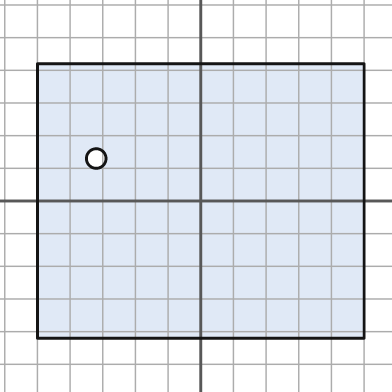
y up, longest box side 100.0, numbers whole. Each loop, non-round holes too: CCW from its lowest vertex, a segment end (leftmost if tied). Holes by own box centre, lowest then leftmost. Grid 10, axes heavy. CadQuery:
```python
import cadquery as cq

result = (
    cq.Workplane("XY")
    .moveTo(-50.0, -42.0)
    .lineTo(50.0, -42.0)
    .lineTo(50.0, 42.0)
    .lineTo(-50.0, 42.0)
    .close()
    .moveTo(-32.0, 13.0)
    .circle(3.0)
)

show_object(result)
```